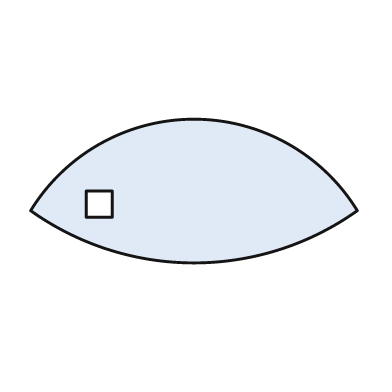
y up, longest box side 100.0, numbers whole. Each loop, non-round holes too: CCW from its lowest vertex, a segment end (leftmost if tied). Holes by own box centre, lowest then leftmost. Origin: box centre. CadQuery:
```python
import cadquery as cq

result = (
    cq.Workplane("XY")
    .moveTo(-50.0, -6.0)
    .threePointArc((0.0, -22.0), (50.0, -6.0))
    .threePointArc((0.0, 22.0), (-50.0, -6.0))
    .close()
    .moveTo(-33.0, -8.0)
    .lineTo(-25.0, -8.0)
    .lineTo(-25.0, 0.0)
    .lineTo(-33.0, 0.0)
    .close()
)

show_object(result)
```